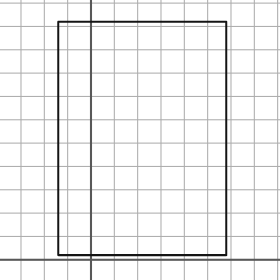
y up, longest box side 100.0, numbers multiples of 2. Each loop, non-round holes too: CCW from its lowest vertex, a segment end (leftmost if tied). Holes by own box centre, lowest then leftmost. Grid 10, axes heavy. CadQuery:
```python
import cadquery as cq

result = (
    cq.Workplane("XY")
    .moveTo(-14.0, 2.0)
    .lineTo(58.0, 2.0)
    .lineTo(58.0, 102.0)
    .lineTo(-14.0, 102.0)
    .close()
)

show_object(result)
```